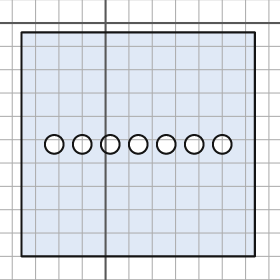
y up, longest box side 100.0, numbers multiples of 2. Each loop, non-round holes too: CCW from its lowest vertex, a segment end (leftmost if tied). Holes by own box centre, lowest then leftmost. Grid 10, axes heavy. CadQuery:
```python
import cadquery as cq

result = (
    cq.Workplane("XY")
    .moveTo(-36.0, -100.0)
    .lineTo(64.0, -100.0)
    .lineTo(64.0, -4.0)
    .lineTo(-36.0, -4.0)
    .close()
    .moveTo(-22.0, -52.0)
    .circle(4.0)
    .moveTo(-10.0, -52.0)
    .circle(4.0)
    .moveTo(2.0, -52.0)
    .circle(4.0)
    .moveTo(14.0, -52.0)
    .circle(4.0)
    .moveTo(26.0, -52.0)
    .circle(4.0)
    .moveTo(38.0, -52.0)
    .circle(4.0)
    .moveTo(50.0, -52.0)
    .circle(4.0)
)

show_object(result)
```